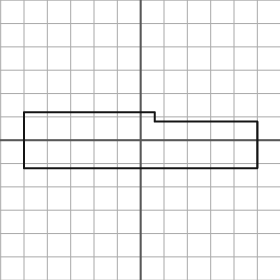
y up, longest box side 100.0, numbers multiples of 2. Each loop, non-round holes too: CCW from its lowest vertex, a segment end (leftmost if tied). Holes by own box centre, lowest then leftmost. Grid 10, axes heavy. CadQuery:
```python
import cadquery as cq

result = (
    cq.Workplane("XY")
    .moveTo(-50.0, -12.0)
    .lineTo(50.0, -12.0)
    .lineTo(50.0, 8.0)
    .lineTo(6.0, 8.0)
    .lineTo(6.0, 12.0)
    .lineTo(-50.0, 12.0)
    .close()
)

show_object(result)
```